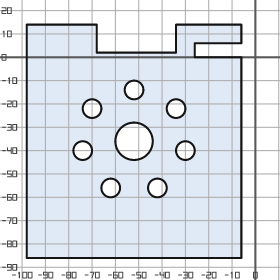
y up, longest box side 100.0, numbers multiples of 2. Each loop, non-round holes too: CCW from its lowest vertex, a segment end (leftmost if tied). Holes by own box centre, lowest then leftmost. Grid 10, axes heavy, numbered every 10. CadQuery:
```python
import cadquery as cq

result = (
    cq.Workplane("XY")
    .moveTo(-98.0, -86.0)
    .lineTo(-6.0, -86.0)
    .lineTo(-6.0, 0.0)
    .lineTo(-26.0, 0.0)
    .lineTo(-26.0, 6.0)
    .lineTo(-6.0, 6.0)
    .lineTo(-6.0, 14.0)
    .lineTo(-34.0, 14.0)
    .lineTo(-34.0, 2.0)
    .lineTo(-68.0, 2.0)
    .lineTo(-68.0, 14.0)
    .lineTo(-98.0, 14.0)
    .close()
    .moveTo(-62.0, -56.0)
    .circle(4.0)
    .moveTo(-42.0, -56.0)
    .circle(4.0)
    .moveTo(-74.0, -40.0)
    .circle(4.0)
    .moveTo(-30.0, -40.0)
    .circle(4.0)
    .moveTo(-52.0, -36.0)
    .circle(8.0)
    .moveTo(-70.0, -22.0)
    .circle(4.0)
    .moveTo(-34.0, -22.0)
    .circle(4.0)
    .moveTo(-52.0, -14.0)
    .circle(4.0)
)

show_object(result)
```